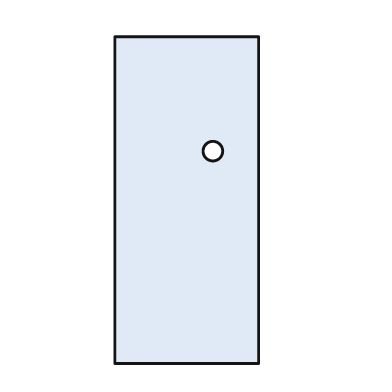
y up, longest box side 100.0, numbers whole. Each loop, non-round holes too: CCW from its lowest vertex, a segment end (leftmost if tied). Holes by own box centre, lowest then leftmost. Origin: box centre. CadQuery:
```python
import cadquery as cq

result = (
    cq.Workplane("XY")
    .moveTo(-22.0, -50.0)
    .lineTo(22.0, -50.0)
    .lineTo(22.0, 50.0)
    .lineTo(-22.0, 50.0)
    .close()
    .moveTo(8.0, 15.0)
    .circle(3.0)
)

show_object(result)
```